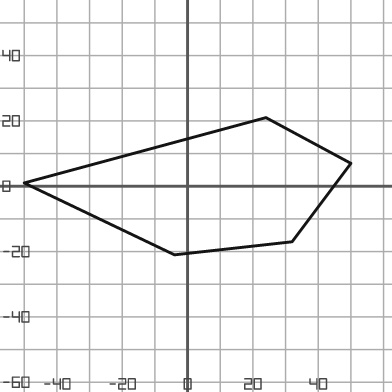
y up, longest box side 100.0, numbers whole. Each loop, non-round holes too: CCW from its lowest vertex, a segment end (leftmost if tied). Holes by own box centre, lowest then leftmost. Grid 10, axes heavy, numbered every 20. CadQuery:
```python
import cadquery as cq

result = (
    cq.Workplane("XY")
    .moveTo(-4.0, -21.0)
    .lineTo(32.0, -17.0)
    .lineTo(50.0, 7.0)
    .lineTo(24.0, 21.0)
    .lineTo(-50.0, 1.0)
    .close()
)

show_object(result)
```